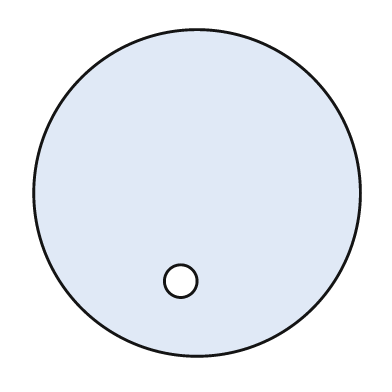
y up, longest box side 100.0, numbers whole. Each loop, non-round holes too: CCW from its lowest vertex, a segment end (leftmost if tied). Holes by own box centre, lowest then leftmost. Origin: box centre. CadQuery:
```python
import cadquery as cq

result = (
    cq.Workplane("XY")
    .moveTo(0.0, 0.0)
    .circle(50.0)
    .moveTo(-5.0, -27.0)
    .circle(5.0)
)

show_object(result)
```